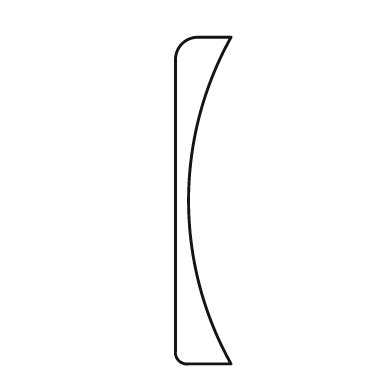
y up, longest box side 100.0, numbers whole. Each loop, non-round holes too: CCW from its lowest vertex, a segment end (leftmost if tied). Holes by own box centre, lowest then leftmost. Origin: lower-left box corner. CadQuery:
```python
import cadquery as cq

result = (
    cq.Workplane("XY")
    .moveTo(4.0, 0.0)
    .lineTo(17.0, 0.0)
    .threePointArc((4.0, 50.0), (17.0, 100.0))
    .lineTo(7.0, 100.0)
    .threePointArc((2.0, 98.0), (0.0, 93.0))
    .lineTo(0.0, 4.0)
    .threePointArc((1.0, 1.0), (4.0, 0.0))
    .close()
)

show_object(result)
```